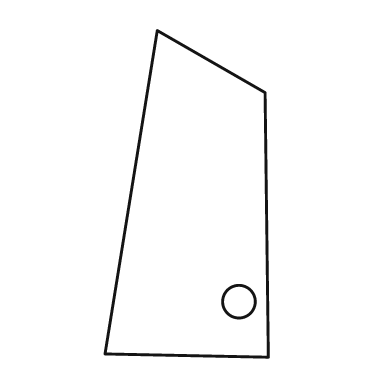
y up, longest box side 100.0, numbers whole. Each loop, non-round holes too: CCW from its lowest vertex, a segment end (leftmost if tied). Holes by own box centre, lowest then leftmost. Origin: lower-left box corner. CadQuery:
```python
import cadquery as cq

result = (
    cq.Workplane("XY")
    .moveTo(50.0, 0.0)
    .lineTo(49.0, 81.0)
    .lineTo(16.0, 100.0)
    .lineTo(0.0, 1.0)
    .close()
    .moveTo(41.0, 17.0)
    .circle(5.0)
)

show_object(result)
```